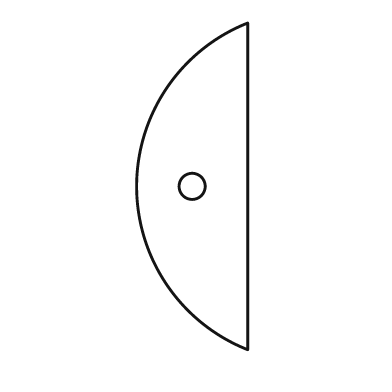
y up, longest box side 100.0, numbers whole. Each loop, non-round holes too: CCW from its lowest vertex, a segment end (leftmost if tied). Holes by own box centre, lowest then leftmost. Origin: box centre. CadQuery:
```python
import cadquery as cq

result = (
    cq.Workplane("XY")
    .moveTo(17.0, -50.0)
    .lineTo(17.0, 50.0)
    .threePointArc((-17.0, 0.0), (17.0, -50.0))
    .close()
    .moveTo(0.0, 0.0)
    .circle(4.0)
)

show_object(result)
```